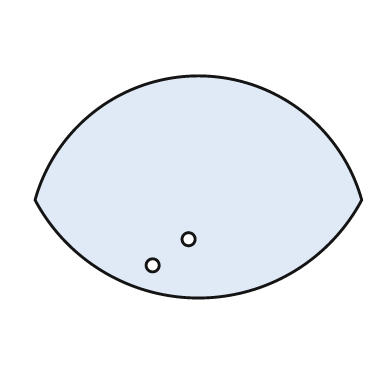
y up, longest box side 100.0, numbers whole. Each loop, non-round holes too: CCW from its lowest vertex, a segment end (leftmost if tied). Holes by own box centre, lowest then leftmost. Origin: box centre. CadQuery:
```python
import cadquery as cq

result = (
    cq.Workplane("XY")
    .moveTo(-50.0, -4.0)
    .threePointArc((0.0, -34.0), (50.0, -4.0))
    .threePointArc((0.0, 34.0), (-50.0, -4.0))
    .close()
    .moveTo(-14.0, -24.0)
    .circle(2.0)
    .moveTo(-3.0, -16.0)
    .circle(2.0)
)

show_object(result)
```